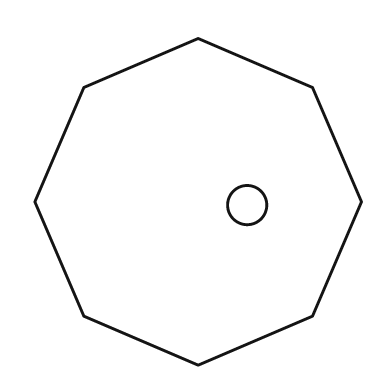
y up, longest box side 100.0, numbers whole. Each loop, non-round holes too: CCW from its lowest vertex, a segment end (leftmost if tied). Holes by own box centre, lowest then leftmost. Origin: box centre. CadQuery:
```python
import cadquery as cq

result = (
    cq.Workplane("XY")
    .moveTo(0.0, -50.0)
    .lineTo(35.0, -35.0)
    .lineTo(50.0, 0.0)
    .lineTo(35.0, 35.0)
    .lineTo(0.0, 50.0)
    .lineTo(-35.0, 35.0)
    .lineTo(-50.0, 0.0)
    .lineTo(-35.0, -35.0)
    .close()
    .moveTo(15.0, -1.0)
    .circle(6.0)
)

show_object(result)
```